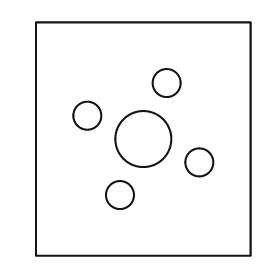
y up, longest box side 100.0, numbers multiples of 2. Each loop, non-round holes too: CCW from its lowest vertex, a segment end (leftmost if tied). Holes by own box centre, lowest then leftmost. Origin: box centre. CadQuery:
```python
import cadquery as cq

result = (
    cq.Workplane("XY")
    .moveTo(-46.0, -50.0)
    .lineTo(46.0, -50.0)
    .lineTo(46.0, 50.0)
    .lineTo(-46.0, 50.0)
    .close()
    .moveTo(-10.0, -24.0)
    .circle(6.0)
    .moveTo(24.0, -10.0)
    .circle(6.0)
    .moveTo(0.0, 0.0)
    .circle(12.0)
    .moveTo(-24.0, 10.0)
    .circle(6.0)
    .moveTo(10.0, 24.0)
    .circle(6.0)
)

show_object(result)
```